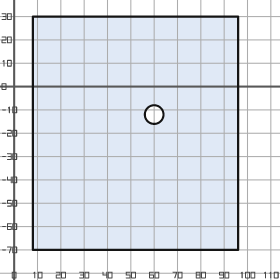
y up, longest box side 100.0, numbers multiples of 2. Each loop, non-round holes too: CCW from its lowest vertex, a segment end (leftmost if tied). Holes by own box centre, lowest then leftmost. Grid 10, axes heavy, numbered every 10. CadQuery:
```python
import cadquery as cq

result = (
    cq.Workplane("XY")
    .moveTo(8.0, -70.0)
    .lineTo(96.0, -70.0)
    .lineTo(96.0, 30.0)
    .lineTo(8.0, 30.0)
    .close()
    .moveTo(60.0, -12.0)
    .circle(4.0)
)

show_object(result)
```